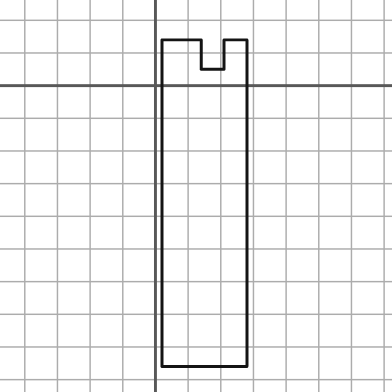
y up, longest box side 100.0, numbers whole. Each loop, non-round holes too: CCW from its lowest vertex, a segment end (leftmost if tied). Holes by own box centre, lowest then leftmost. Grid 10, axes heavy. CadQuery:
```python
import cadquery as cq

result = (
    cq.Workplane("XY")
    .moveTo(2.0, -86.0)
    .lineTo(28.0, -86.0)
    .lineTo(28.0, 14.0)
    .lineTo(21.0, 14.0)
    .lineTo(21.0, 5.0)
    .lineTo(14.0, 5.0)
    .lineTo(14.0, 14.0)
    .lineTo(2.0, 14.0)
    .close()
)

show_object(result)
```